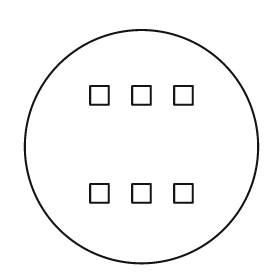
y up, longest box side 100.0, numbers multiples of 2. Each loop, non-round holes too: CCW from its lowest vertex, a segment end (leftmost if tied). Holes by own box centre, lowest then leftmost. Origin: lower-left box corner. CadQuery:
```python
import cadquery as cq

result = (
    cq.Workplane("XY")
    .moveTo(50.0, 50.0)
    .circle(50.0)
    .moveTo(28.0, 26.0)
    .lineTo(36.0, 26.0)
    .lineTo(36.0, 34.0)
    .lineTo(28.0, 34.0)
    .close()
    .moveTo(46.0, 26.0)
    .lineTo(54.0, 26.0)
    .lineTo(54.0, 34.0)
    .lineTo(46.0, 34.0)
    .close()
    .moveTo(64.0, 26.0)
    .lineTo(72.0, 26.0)
    .lineTo(72.0, 34.0)
    .lineTo(64.0, 34.0)
    .close()
    .moveTo(28.0, 68.0)
    .lineTo(36.0, 68.0)
    .lineTo(36.0, 76.0)
    .lineTo(28.0, 76.0)
    .close()
    .moveTo(46.0, 68.0)
    .lineTo(54.0, 68.0)
    .lineTo(54.0, 76.0)
    .lineTo(46.0, 76.0)
    .close()
    .moveTo(64.0, 68.0)
    .lineTo(72.0, 68.0)
    .lineTo(72.0, 76.0)
    .lineTo(64.0, 76.0)
    .close()
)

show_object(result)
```